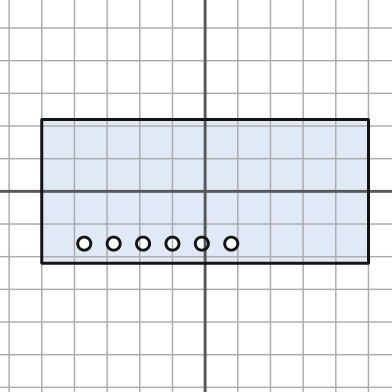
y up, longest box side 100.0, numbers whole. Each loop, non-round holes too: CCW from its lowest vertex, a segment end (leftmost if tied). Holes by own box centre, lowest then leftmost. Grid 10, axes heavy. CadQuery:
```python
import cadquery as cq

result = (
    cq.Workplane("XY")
    .moveTo(-50.0, -22.0)
    .lineTo(50.0, -22.0)
    .lineTo(50.0, 22.0)
    .lineTo(-50.0, 22.0)
    .close()
    .moveTo(-37.0, -16.0)
    .circle(2.0)
    .moveTo(-28.0, -16.0)
    .circle(2.0)
    .moveTo(-19.0, -16.0)
    .circle(2.0)
    .moveTo(-10.0, -16.0)
    .circle(2.0)
    .moveTo(-1.0, -16.0)
    .circle(2.0)
    .moveTo(8.0, -16.0)
    .circle(2.0)
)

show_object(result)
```